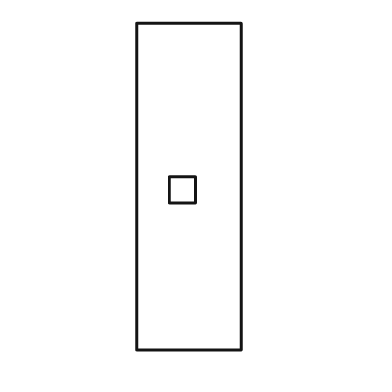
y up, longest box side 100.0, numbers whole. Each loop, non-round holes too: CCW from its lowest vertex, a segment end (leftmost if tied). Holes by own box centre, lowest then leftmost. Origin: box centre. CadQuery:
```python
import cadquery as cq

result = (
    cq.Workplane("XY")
    .moveTo(-16.0, -50.0)
    .lineTo(16.0, -50.0)
    .lineTo(16.0, 50.0)
    .lineTo(-16.0, 50.0)
    .close()
    .moveTo(-6.0, -5.0)
    .lineTo(2.0, -5.0)
    .lineTo(2.0, 3.0)
    .lineTo(-6.0, 3.0)
    .close()
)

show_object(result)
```